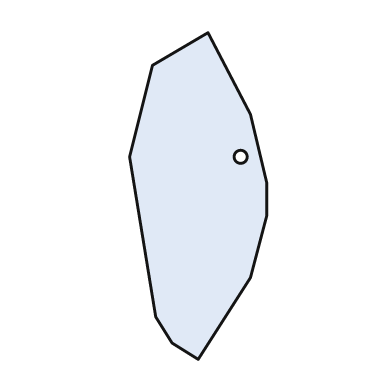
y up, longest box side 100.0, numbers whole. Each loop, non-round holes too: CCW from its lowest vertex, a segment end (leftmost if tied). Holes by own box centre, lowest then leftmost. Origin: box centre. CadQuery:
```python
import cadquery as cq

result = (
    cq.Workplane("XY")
    .moveTo(0.0, -50.0)
    .lineTo(16.0, -25.0)
    .lineTo(21.0, -6.0)
    .lineTo(21.0, 4.0)
    .lineTo(16.0, 25.0)
    .lineTo(3.0, 50.0)
    .lineTo(-14.0, 40.0)
    .lineTo(-21.0, 12.0)
    .lineTo(-13.0, -37.0)
    .lineTo(-8.0, -45.0)
    .close()
    .moveTo(13.0, 12.0)
    .circle(2.0)
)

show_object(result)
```